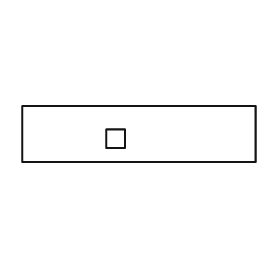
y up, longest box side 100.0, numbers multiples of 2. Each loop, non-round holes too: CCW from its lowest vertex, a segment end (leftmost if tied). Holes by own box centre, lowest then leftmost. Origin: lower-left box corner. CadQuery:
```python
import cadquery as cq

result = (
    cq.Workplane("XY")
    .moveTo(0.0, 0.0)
    .lineTo(100.0, 0.0)
    .lineTo(100.0, 24.0)
    .lineTo(0.0, 24.0)
    .close()
    .moveTo(36.0, 6.0)
    .lineTo(44.0, 6.0)
    .lineTo(44.0, 14.0)
    .lineTo(36.0, 14.0)
    .close()
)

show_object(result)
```